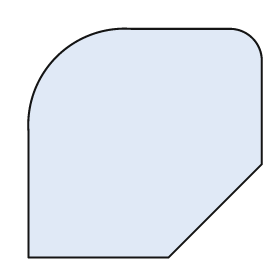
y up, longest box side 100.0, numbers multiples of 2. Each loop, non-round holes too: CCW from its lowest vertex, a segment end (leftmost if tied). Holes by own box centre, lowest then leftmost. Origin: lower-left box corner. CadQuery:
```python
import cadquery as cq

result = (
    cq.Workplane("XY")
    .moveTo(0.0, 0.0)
    .lineTo(60.0, 0.0)
    .lineTo(100.0, 40.0)
    .lineTo(100.0, 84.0)
    .threePointArc((96.0, 94.0), (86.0, 98.0))
    .lineTo(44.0, 98.0)
    .threePointArc((12.0, 86.0), (0.0, 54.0))
    .close()
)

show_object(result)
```